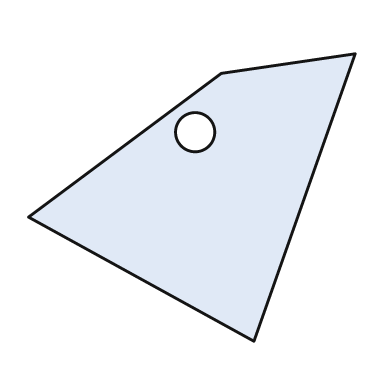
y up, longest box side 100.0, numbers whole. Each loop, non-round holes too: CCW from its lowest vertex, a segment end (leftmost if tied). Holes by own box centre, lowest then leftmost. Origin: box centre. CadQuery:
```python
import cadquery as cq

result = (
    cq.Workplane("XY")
    .moveTo(19.0, -44.0)
    .lineTo(50.0, 44.0)
    .lineTo(9.0, 38.0)
    .lineTo(-50.0, -6.0)
    .close()
    .moveTo(1.0, 20.0)
    .circle(6.0)
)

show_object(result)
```